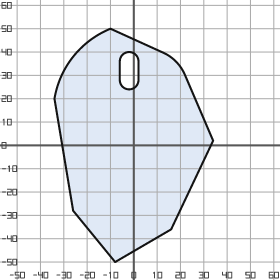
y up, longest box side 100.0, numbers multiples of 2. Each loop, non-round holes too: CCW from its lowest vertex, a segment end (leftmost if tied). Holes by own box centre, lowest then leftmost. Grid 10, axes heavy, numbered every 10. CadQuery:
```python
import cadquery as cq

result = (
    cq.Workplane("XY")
    .moveTo(-8.0, -50.0)
    .lineTo(16.0, -36.0)
    .lineTo(34.0, 2.0)
    .lineTo(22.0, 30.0)
    .threePointArc((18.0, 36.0), (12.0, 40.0))
    .lineTo(-10.0, 50.0)
    .threePointArc((-26.0, 38.0), (-34.0, 20.0))
    .lineTo(-26.0, -28.0)
    .close()
    .moveTo(-6.0, 28.0)
    .threePointArc((-2.0, 24.0), (2.0, 28.0))
    .lineTo(2.0, 36.0)
    .threePointArc((-2.0, 40.0), (-6.0, 36.0))
    .close()
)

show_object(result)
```